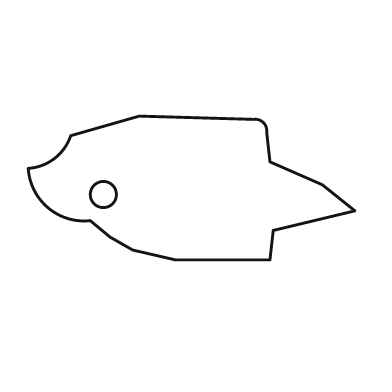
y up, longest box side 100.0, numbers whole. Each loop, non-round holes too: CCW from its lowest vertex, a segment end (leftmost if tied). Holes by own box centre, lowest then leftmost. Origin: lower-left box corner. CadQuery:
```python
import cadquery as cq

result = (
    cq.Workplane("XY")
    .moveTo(45.0, 0.0)
    .lineTo(74.0, 0.0)
    .lineTo(75.0, 9.0)
    .lineTo(100.0, 15.0)
    .lineTo(90.0, 23.0)
    .lineTo(74.0, 30.0)
    .lineTo(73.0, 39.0)
    .threePointArc((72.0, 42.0), (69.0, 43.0))
    .lineTo(34.0, 44.0)
    .lineTo(13.0, 38.0)
    .threePointArc((8.0, 31.0), (0.0, 28.0))
    .threePointArc((6.0, 16.0), (19.0, 12.0))
    .lineTo(25.0, 7.0)
    .lineTo(32.0, 3.0)
    .close()
    .moveTo(23.0, 20.0)
    .circle(4.0)
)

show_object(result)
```